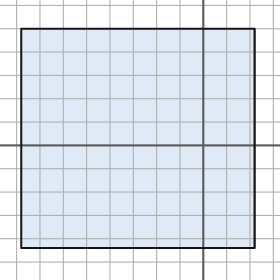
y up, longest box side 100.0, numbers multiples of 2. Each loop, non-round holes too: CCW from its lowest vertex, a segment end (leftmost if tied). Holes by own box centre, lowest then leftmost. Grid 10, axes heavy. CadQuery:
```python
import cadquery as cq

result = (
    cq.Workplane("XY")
    .moveTo(-78.0, -44.0)
    .lineTo(22.0, -44.0)
    .lineTo(22.0, 50.0)
    .lineTo(-78.0, 50.0)
    .close()
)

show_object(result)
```